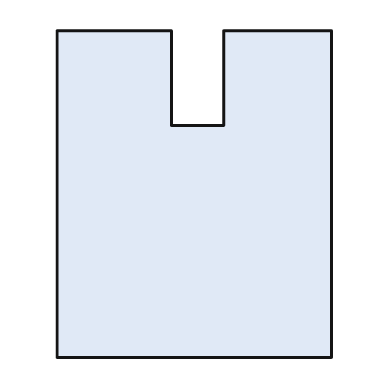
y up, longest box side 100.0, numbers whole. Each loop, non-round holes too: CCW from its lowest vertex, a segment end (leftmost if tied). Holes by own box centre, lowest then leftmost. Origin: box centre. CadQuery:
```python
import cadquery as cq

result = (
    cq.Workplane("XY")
    .moveTo(-42.0, -50.0)
    .lineTo(42.0, -50.0)
    .lineTo(42.0, 50.0)
    .lineTo(9.0, 50.0)
    .lineTo(9.0, 21.0)
    .lineTo(-7.0, 21.0)
    .lineTo(-7.0, 50.0)
    .lineTo(-42.0, 50.0)
    .close()
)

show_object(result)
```